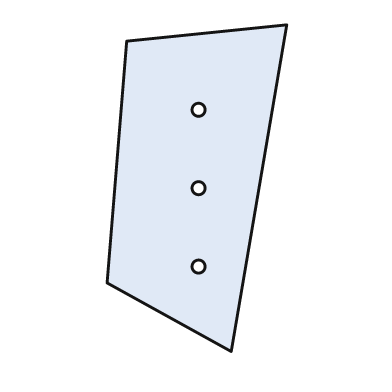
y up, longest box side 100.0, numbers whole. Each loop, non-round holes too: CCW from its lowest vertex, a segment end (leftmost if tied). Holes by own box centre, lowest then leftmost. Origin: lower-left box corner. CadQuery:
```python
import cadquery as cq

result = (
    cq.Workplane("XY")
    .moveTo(38.0, 0.0)
    .lineTo(55.0, 100.0)
    .lineTo(6.0, 95.0)
    .lineTo(0.0, 21.0)
    .close()
    .moveTo(28.0, 26.0)
    .circle(2.0)
    .moveTo(28.0, 50.0)
    .circle(2.0)
    .moveTo(28.0, 74.0)
    .circle(2.0)
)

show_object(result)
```